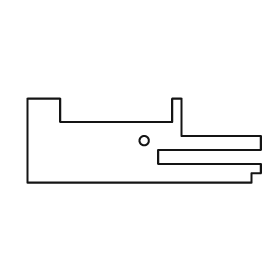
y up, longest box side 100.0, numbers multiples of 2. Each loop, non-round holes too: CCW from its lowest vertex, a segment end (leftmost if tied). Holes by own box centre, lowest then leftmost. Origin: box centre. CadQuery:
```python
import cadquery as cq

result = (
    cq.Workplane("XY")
    .moveTo(-50.0, -18.0)
    .lineTo(46.0, -18.0)
    .lineTo(46.0, -14.0)
    .lineTo(50.0, -14.0)
    .lineTo(50.0, -10.0)
    .lineTo(6.0, -10.0)
    .lineTo(6.0, -4.0)
    .lineTo(50.0, -4.0)
    .lineTo(50.0, 2.0)
    .lineTo(16.0, 2.0)
    .lineTo(16.0, 18.0)
    .lineTo(12.0, 18.0)
    .lineTo(12.0, 8.0)
    .lineTo(-36.0, 8.0)
    .lineTo(-36.0, 18.0)
    .lineTo(-50.0, 18.0)
    .close()
    .moveTo(0.0, 0.0)
    .circle(2.0)
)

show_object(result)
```